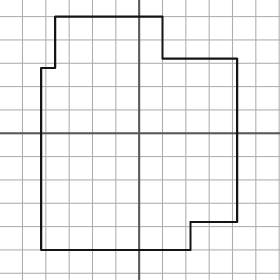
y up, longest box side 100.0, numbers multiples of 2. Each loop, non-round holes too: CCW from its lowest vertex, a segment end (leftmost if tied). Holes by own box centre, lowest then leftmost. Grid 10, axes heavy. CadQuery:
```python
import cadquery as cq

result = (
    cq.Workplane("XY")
    .moveTo(-42.0, -50.0)
    .lineTo(22.0, -50.0)
    .lineTo(22.0, -38.0)
    .lineTo(42.0, -38.0)
    .lineTo(42.0, 32.0)
    .lineTo(10.0, 32.0)
    .lineTo(10.0, 50.0)
    .lineTo(-36.0, 50.0)
    .lineTo(-36.0, 28.0)
    .lineTo(-42.0, 28.0)
    .close()
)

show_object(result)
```